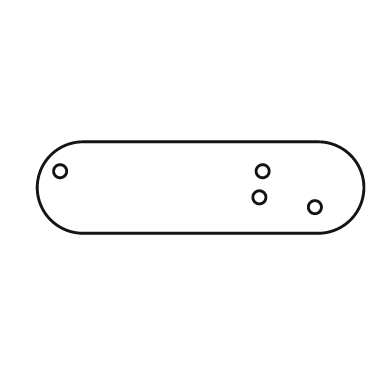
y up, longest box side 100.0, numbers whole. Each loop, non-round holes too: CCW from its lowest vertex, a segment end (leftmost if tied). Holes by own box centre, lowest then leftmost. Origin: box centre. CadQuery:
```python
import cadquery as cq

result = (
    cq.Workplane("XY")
    .moveTo(-36.0, -14.0)
    .lineTo(36.0, -14.0)
    .threePointArc((50.0, 0.0), (36.0, 14.0))
    .lineTo(-36.0, 14.0)
    .threePointArc((-50.0, 0.0), (-36.0, -14.0))
    .close()
    .moveTo(35.0, -6.0)
    .circle(2.0)
    .moveTo(18.0, -3.0)
    .circle(2.0)
    .moveTo(-43.0, 5.0)
    .circle(2.0)
    .moveTo(19.0, 5.0)
    .circle(2.0)
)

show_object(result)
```